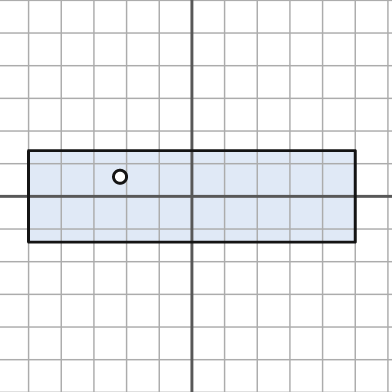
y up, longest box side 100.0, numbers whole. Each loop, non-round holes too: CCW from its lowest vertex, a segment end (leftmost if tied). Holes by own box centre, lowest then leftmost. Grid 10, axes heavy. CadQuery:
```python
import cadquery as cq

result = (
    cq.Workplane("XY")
    .moveTo(-50.0, -14.0)
    .lineTo(50.0, -14.0)
    .lineTo(50.0, 14.0)
    .lineTo(-50.0, 14.0)
    .close()
    .moveTo(-22.0, 6.0)
    .circle(2.0)
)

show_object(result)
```